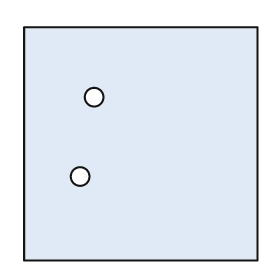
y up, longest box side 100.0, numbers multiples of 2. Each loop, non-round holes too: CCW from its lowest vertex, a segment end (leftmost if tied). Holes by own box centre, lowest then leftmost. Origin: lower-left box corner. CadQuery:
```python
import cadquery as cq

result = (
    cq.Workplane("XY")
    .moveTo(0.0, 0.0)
    .lineTo(100.0, 0.0)
    .lineTo(100.0, 100.0)
    .lineTo(0.0, 100.0)
    .close()
    .moveTo(24.0, 36.0)
    .circle(4.0)
    .moveTo(30.0, 70.0)
    .circle(4.0)
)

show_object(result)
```